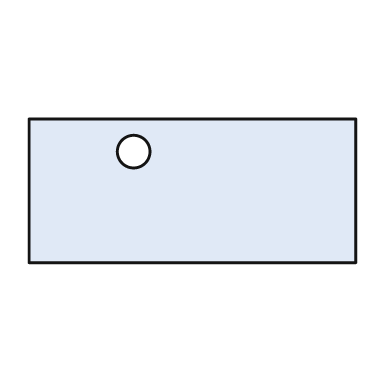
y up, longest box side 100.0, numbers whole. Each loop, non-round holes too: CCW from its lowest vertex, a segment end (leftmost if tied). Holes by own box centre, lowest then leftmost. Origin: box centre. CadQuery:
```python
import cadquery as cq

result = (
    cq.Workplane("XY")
    .moveTo(-50.0, -22.0)
    .lineTo(50.0, -22.0)
    .lineTo(50.0, 22.0)
    .lineTo(-50.0, 22.0)
    .close()
    .moveTo(-18.0, 12.0)
    .circle(5.0)
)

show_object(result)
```